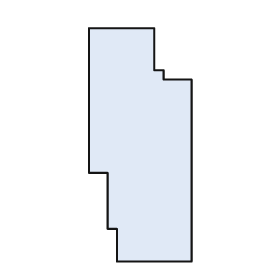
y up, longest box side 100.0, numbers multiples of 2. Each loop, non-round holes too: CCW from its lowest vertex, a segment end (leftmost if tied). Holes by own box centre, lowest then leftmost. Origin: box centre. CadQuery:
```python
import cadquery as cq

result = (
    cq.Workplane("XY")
    .moveTo(-10.0, -50.0)
    .lineTo(22.0, -50.0)
    .lineTo(22.0, 28.0)
    .lineTo(10.0, 28.0)
    .lineTo(10.0, 32.0)
    .lineTo(6.0, 32.0)
    .lineTo(6.0, 50.0)
    .lineTo(-22.0, 50.0)
    .lineTo(-22.0, -12.0)
    .lineTo(-14.0, -12.0)
    .lineTo(-14.0, -36.0)
    .lineTo(-10.0, -36.0)
    .close()
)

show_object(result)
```